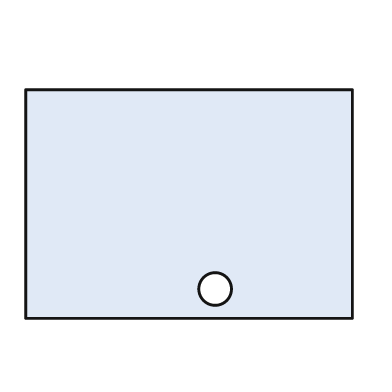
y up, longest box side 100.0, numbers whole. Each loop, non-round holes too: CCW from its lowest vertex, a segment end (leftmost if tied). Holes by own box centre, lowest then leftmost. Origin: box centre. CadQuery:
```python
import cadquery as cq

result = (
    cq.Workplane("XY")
    .moveTo(-50.0, -35.0)
    .lineTo(50.0, -35.0)
    .lineTo(50.0, 35.0)
    .lineTo(-50.0, 35.0)
    .close()
    .moveTo(8.0, -26.0)
    .circle(5.0)
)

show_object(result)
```